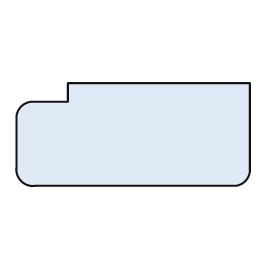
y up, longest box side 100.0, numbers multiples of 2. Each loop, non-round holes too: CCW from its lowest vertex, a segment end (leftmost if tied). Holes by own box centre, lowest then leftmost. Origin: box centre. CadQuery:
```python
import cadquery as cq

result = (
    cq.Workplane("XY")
    .moveTo(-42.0, -22.0)
    .lineTo(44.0, -22.0)
    .threePointArc((48.0, -20.0), (50.0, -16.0))
    .lineTo(50.0, 22.0)
    .lineTo(-28.0, 22.0)
    .lineTo(-28.0, 14.0)
    .lineTo(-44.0, 14.0)
    .threePointArc((-48.0, 12.0), (-50.0, 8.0))
    .lineTo(-50.0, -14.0)
    .threePointArc((-48.0, -20.0), (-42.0, -22.0))
    .close()
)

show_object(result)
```